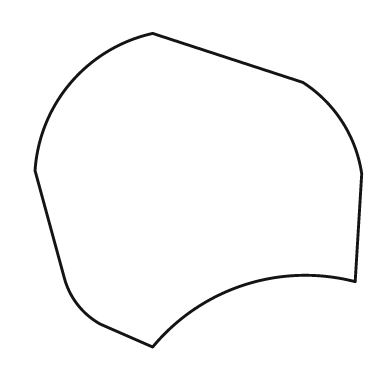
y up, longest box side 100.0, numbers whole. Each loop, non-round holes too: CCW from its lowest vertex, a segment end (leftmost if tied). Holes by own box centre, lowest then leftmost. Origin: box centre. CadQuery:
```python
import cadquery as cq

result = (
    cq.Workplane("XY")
    .moveTo(-14.0, -48.0)
    .threePointArc((14.0, -29.0), (48.0, -28.0))
    .lineTo(50.0, 5.0)
    .threePointArc((44.0, 21.0), (32.0, 33.0))
    .lineTo(-14.0, 48.0)
    .threePointArc((-39.0, 33.0), (-50.0, 6.0))
    .lineTo(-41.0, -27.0)
    .threePointArc((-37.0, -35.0), (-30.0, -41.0))
    .close()
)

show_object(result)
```